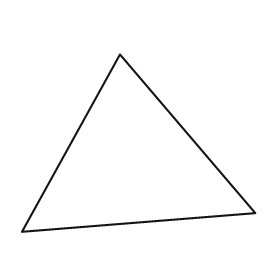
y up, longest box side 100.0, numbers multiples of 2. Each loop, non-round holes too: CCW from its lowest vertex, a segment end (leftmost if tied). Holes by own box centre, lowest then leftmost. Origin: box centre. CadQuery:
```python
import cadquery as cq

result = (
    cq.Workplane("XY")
    .moveTo(-50.0, -38.0)
    .lineTo(50.0, -30.0)
    .lineTo(-8.0, 38.0)
    .close()
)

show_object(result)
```